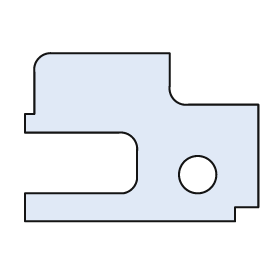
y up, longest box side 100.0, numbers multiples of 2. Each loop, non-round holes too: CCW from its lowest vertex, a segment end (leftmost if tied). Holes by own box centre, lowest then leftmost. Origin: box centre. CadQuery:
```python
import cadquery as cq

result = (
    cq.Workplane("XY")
    .moveTo(-50.0, -36.0)
    .lineTo(40.0, -36.0)
    .lineTo(40.0, -30.0)
    .lineTo(50.0, -30.0)
    .lineTo(50.0, 14.0)
    .lineTo(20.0, 14.0)
    .threePointArc((14.0, 16.0), (12.0, 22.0))
    .lineTo(12.0, 36.0)
    .lineTo(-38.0, 36.0)
    .threePointArc((-44.0, 34.0), (-46.0, 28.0))
    .lineTo(-46.0, 10.0)
    .lineTo(-50.0, 10.0)
    .lineTo(-50.0, 2.0)
    .lineTo(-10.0, 2.0)
    .threePointArc((-4.0, 0.0), (-2.0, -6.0))
    .lineTo(-2.0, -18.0)
    .threePointArc((-4.0, -22.0), (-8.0, -24.0))
    .lineTo(-50.0, -24.0)
    .close()
    .moveTo(24.0, -16.0)
    .circle(8.0)
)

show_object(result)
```